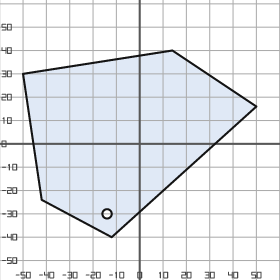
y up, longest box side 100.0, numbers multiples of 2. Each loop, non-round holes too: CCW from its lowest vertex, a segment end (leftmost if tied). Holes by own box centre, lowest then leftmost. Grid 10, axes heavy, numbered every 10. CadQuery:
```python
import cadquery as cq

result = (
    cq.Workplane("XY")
    .moveTo(-12.0, -40.0)
    .lineTo(50.0, 16.0)
    .lineTo(14.0, 40.0)
    .lineTo(-50.0, 30.0)
    .lineTo(-42.0, -24.0)
    .close()
    .moveTo(-14.0, -30.0)
    .circle(2.0)
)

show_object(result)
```